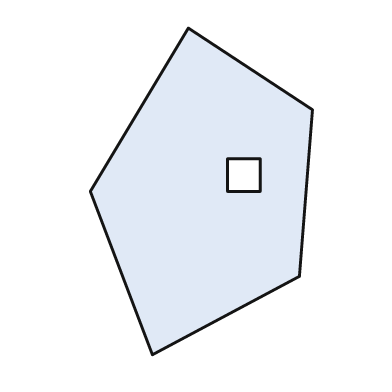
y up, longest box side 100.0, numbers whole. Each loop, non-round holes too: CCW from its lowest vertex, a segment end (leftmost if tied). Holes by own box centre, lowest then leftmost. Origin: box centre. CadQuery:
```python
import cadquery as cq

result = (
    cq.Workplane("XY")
    .moveTo(-15.0, -50.0)
    .lineTo(30.0, -26.0)
    .lineTo(34.0, 25.0)
    .lineTo(-4.0, 50.0)
    .lineTo(-34.0, 0.0)
    .close()
    .moveTo(8.0, 0.0)
    .lineTo(18.0, 0.0)
    .lineTo(18.0, 10.0)
    .lineTo(8.0, 10.0)
    .close()
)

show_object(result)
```